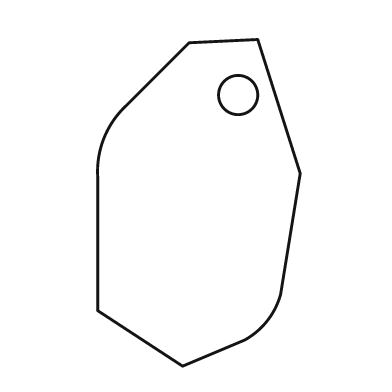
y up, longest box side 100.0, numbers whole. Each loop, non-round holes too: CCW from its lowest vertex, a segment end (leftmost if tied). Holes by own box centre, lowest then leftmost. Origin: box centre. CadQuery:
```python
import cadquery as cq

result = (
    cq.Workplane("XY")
    .moveTo(-5.0, -50.0)
    .lineTo(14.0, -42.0)
    .threePointArc((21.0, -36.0), (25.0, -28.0))
    .lineTo(31.0, 9.0)
    .lineTo(18.0, 50.0)
    .lineTo(-3.0, 49.0)
    .lineTo(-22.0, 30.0)
    .threePointArc((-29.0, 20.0), (-31.0, 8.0))
    .lineTo(-31.0, -33.0)
    .close()
    .moveTo(12.0, 33.0)
    .circle(6.0)
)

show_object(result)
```